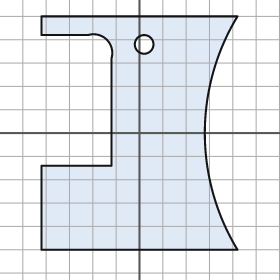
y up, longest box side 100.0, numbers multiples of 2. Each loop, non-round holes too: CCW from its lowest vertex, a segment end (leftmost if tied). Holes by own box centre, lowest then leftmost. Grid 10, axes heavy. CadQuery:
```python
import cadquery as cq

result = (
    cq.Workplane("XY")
    .moveTo(-42.0, -50.0)
    .lineTo(42.0, -50.0)
    .threePointArc((28.0, 0.0), (42.0, 50.0))
    .lineTo(-42.0, 50.0)
    .lineTo(-42.0, 42.0)
    .lineTo(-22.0, 42.0)
    .threePointArc((-14.0, 40.0), (-12.0, 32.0))
    .lineTo(-12.0, -14.0)
    .lineTo(-42.0, -14.0)
    .close()
    .moveTo(2.0, 38.0)
    .circle(4.0)
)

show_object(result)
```